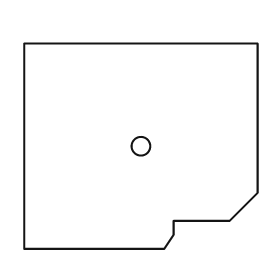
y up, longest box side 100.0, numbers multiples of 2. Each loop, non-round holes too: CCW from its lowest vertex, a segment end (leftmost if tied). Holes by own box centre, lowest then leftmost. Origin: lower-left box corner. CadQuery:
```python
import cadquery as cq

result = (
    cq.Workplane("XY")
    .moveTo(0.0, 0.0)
    .lineTo(60.0, 0.0)
    .lineTo(64.0, 6.0)
    .lineTo(64.0, 12.0)
    .lineTo(88.0, 12.0)
    .lineTo(100.0, 24.0)
    .lineTo(100.0, 88.0)
    .lineTo(0.0, 88.0)
    .close()
    .moveTo(50.0, 44.0)
    .circle(4.0)
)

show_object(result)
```